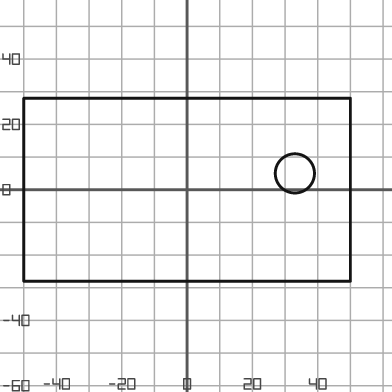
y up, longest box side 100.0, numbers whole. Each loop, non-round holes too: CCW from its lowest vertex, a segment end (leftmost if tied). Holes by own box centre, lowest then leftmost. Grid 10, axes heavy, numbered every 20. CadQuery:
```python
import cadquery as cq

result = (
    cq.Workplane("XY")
    .moveTo(-50.0, -28.0)
    .lineTo(50.0, -28.0)
    .lineTo(50.0, 28.0)
    .lineTo(-50.0, 28.0)
    .close()
    .moveTo(33.0, 5.0)
    .circle(6.0)
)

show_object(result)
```